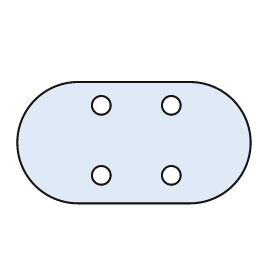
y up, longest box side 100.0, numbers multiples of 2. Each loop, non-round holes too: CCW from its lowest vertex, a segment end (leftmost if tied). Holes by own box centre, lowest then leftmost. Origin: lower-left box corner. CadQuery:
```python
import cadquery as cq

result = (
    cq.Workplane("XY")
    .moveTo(26.0, 0.0)
    .lineTo(74.0, 0.0)
    .threePointArc((100.0, 26.0), (74.0, 52.0))
    .lineTo(26.0, 52.0)
    .threePointArc((0.0, 26.0), (26.0, 0.0))
    .close()
    .moveTo(36.0, 12.0)
    .circle(4.0)
    .moveTo(66.0, 12.0)
    .circle(4.0)
    .moveTo(36.0, 42.0)
    .circle(4.0)
    .moveTo(66.0, 42.0)
    .circle(4.0)
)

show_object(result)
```